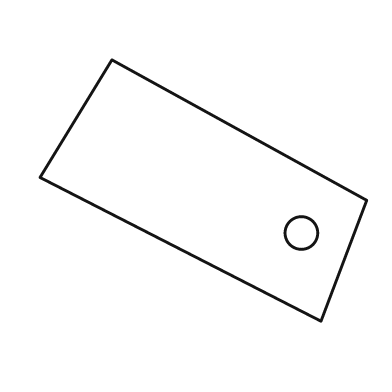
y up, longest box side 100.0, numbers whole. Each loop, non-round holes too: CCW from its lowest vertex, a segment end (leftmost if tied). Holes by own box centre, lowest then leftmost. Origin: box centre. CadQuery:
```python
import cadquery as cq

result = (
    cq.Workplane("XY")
    .moveTo(36.0, -40.0)
    .lineTo(50.0, -3.0)
    .lineTo(-28.0, 40.0)
    .lineTo(-50.0, 4.0)
    .close()
    .moveTo(30.0, -13.0)
    .circle(5.0)
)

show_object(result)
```